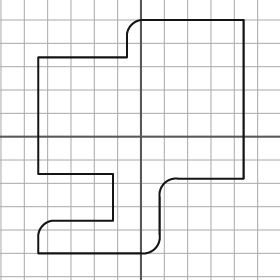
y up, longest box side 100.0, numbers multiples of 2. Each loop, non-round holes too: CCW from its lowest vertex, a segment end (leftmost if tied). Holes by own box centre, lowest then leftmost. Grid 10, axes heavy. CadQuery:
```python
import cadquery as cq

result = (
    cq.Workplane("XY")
    .moveTo(-44.0, -50.0)
    .lineTo(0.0, -50.0)
    .threePointArc((6.0, -48.0), (8.0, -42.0))
    .lineTo(8.0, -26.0)
    .threePointArc((10.0, -20.0), (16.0, -18.0))
    .lineTo(44.0, -18.0)
    .lineTo(44.0, 50.0)
    .lineTo(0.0, 50.0)
    .threePointArc((-4.0, 48.0), (-6.0, 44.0))
    .lineTo(-6.0, 34.0)
    .lineTo(-44.0, 34.0)
    .lineTo(-44.0, -16.0)
    .lineTo(-12.0, -16.0)
    .lineTo(-12.0, -36.0)
    .lineTo(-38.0, -36.0)
    .threePointArc((-42.0, -38.0), (-44.0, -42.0))
    .close()
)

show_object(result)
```